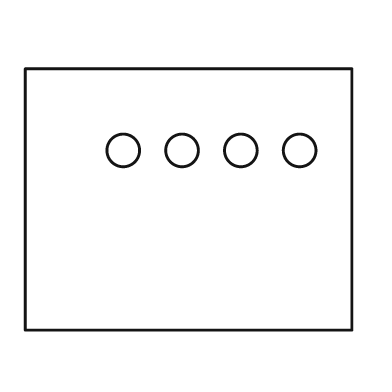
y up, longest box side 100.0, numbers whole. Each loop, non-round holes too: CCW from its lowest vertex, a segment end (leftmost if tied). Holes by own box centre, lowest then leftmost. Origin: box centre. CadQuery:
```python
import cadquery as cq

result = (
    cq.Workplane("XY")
    .moveTo(-50.0, -40.0)
    .lineTo(50.0, -40.0)
    .lineTo(50.0, 40.0)
    .lineTo(-50.0, 40.0)
    .close()
    .moveTo(-20.0, 15.0)
    .circle(5.0)
    .moveTo(-2.0, 15.0)
    .circle(5.0)
    .moveTo(16.0, 15.0)
    .circle(5.0)
    .moveTo(34.0, 15.0)
    .circle(5.0)
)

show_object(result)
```